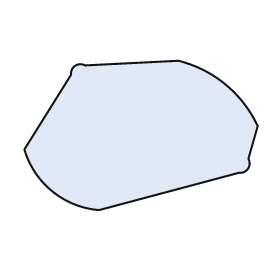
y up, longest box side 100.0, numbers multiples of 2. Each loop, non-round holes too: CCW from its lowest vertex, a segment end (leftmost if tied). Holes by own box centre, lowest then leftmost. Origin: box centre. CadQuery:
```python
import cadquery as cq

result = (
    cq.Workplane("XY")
    .moveTo(-18.0, -32.0)
    .lineTo(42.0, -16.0)
    .threePointArc((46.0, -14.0), (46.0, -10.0))
    .lineTo(50.0, 4.0)
    .threePointArc((36.0, 22.0), (16.0, 32.0))
    .lineTo(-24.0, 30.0)
    .threePointArc((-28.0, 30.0), (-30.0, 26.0))
    .lineTo(-50.0, -6.0)
    .threePointArc((-38.0, -24.0), (-18.0, -32.0))
    .close()
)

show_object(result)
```